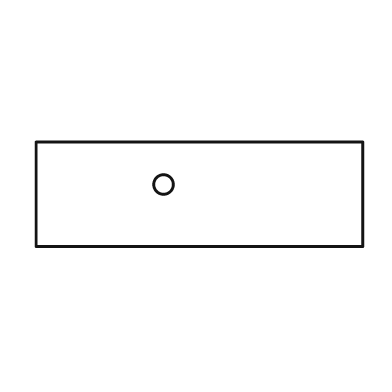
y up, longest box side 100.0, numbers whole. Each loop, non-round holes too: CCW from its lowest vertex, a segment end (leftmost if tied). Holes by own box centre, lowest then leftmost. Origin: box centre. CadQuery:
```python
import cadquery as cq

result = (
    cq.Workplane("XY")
    .moveTo(-50.0, -16.0)
    .lineTo(50.0, -16.0)
    .lineTo(50.0, 16.0)
    .lineTo(-50.0, 16.0)
    .close()
    .moveTo(-11.0, 3.0)
    .circle(3.0)
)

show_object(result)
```